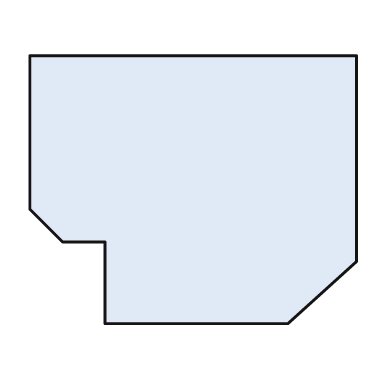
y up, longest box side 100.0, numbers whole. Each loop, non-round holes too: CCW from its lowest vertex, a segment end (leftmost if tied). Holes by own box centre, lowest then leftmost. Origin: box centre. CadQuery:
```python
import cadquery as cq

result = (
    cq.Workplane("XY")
    .moveTo(-27.0, -41.0)
    .lineTo(29.0, -41.0)
    .lineTo(50.0, -22.0)
    .lineTo(50.0, 41.0)
    .lineTo(-50.0, 41.0)
    .lineTo(-50.0, -6.0)
    .lineTo(-40.0, -16.0)
    .lineTo(-27.0, -16.0)
    .close()
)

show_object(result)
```